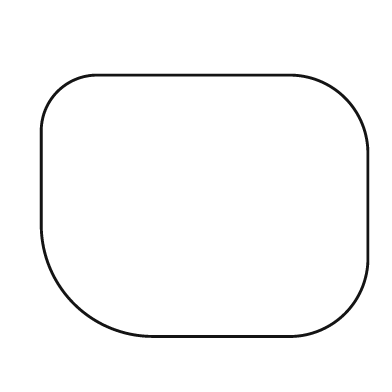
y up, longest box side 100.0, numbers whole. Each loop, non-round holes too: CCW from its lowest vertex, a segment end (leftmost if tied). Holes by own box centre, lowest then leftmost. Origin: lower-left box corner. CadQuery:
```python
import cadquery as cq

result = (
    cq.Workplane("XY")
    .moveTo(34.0, 0.0)
    .lineTo(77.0, 0.0)
    .threePointArc((93.0, 7.0), (100.0, 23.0))
    .lineTo(100.0, 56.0)
    .threePointArc((93.0, 73.0), (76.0, 80.0))
    .lineTo(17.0, 80.0)
    .threePointArc((5.0, 75.0), (0.0, 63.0))
    .lineTo(0.0, 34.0)
    .threePointArc((10.0, 10.0), (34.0, 0.0))
    .close()
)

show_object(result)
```